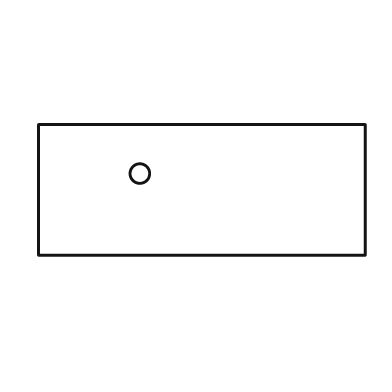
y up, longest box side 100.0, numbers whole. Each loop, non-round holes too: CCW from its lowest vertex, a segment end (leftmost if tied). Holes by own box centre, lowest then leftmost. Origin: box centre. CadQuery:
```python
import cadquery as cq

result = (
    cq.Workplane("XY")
    .moveTo(-50.0, -20.0)
    .lineTo(50.0, -20.0)
    .lineTo(50.0, 20.0)
    .lineTo(-50.0, 20.0)
    .close()
    .moveTo(-19.0, 5.0)
    .circle(3.0)
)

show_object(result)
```